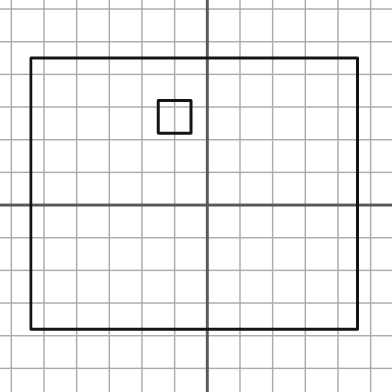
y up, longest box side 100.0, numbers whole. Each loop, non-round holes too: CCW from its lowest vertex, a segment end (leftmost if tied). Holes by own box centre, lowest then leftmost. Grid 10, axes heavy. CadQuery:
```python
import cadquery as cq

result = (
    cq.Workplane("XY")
    .moveTo(-54.0, -38.0)
    .lineTo(46.0, -38.0)
    .lineTo(46.0, 45.0)
    .lineTo(-54.0, 45.0)
    .close()
    .moveTo(-15.0, 22.0)
    .lineTo(-5.0, 22.0)
    .lineTo(-5.0, 32.0)
    .lineTo(-15.0, 32.0)
    .close()
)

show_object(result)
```